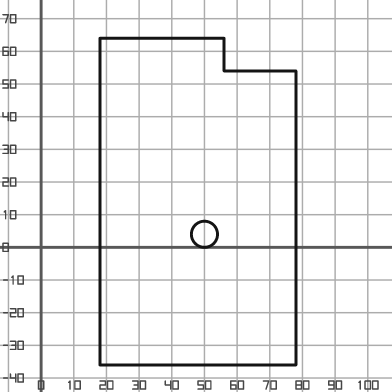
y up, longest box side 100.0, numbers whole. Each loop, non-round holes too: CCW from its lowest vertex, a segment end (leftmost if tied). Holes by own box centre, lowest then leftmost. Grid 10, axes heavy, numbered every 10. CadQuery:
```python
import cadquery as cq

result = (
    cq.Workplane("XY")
    .moveTo(18.0, -36.0)
    .lineTo(78.0, -36.0)
    .lineTo(78.0, 54.0)
    .lineTo(56.0, 54.0)
    .lineTo(56.0, 64.0)
    .lineTo(18.0, 64.0)
    .close()
    .moveTo(50.0, 4.0)
    .circle(4.0)
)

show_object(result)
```